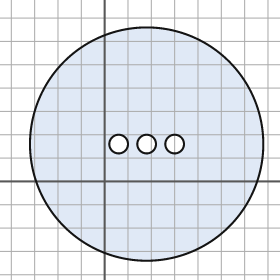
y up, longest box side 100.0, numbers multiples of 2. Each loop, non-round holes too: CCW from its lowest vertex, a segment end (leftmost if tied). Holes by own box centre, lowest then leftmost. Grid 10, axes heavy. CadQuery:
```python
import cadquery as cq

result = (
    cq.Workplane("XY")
    .moveTo(18.0, 16.0)
    .circle(50.0)
    .moveTo(6.0, 16.0)
    .circle(4.0)
    .moveTo(18.0, 16.0)
    .circle(4.0)
    .moveTo(30.0, 16.0)
    .circle(4.0)
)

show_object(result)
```